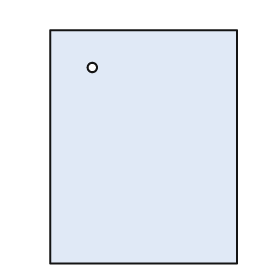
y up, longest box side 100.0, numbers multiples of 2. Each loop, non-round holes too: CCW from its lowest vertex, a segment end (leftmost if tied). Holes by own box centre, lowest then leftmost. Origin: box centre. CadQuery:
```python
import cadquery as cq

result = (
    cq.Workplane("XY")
    .moveTo(-40.0, -50.0)
    .lineTo(40.0, -50.0)
    .lineTo(40.0, 50.0)
    .lineTo(-40.0, 50.0)
    .close()
    .moveTo(-22.0, 34.0)
    .circle(2.0)
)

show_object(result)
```